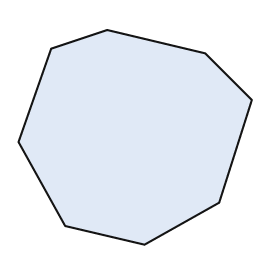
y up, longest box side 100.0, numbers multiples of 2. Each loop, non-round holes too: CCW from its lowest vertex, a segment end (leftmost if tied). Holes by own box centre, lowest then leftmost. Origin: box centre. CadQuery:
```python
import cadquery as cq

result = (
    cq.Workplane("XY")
    .moveTo(4.0, -46.0)
    .lineTo(36.0, -28.0)
    .lineTo(50.0, 16.0)
    .lineTo(30.0, 36.0)
    .lineTo(-12.0, 46.0)
    .lineTo(-36.0, 38.0)
    .lineTo(-50.0, -2.0)
    .lineTo(-30.0, -38.0)
    .close()
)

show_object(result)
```